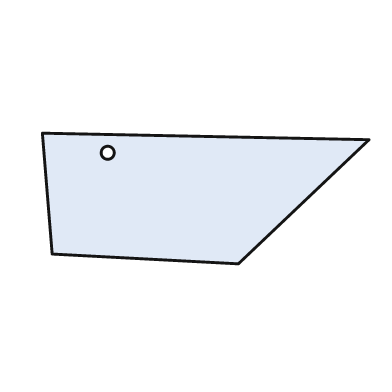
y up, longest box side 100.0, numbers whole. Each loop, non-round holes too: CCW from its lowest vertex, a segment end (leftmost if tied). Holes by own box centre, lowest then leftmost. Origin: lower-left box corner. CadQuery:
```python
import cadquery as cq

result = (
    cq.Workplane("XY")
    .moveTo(60.0, 0.0)
    .lineTo(100.0, 38.0)
    .lineTo(0.0, 40.0)
    .lineTo(3.0, 3.0)
    .close()
    .moveTo(20.0, 34.0)
    .circle(2.0)
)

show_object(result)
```